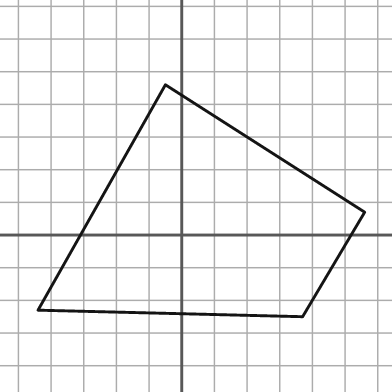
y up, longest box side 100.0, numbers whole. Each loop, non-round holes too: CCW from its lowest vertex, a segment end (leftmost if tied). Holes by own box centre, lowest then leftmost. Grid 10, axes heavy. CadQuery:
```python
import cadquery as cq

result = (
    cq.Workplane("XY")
    .moveTo(37.0, -25.0)
    .lineTo(56.0, 7.0)
    .lineTo(-5.0, 46.0)
    .lineTo(-44.0, -23.0)
    .close()
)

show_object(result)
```